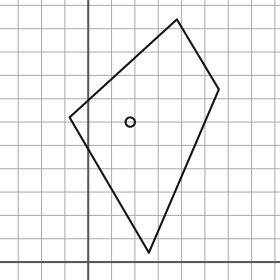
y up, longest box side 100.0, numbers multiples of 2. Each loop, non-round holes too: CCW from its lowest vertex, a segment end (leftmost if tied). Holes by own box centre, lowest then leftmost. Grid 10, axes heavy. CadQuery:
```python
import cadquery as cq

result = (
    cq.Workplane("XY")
    .moveTo(26.0, 4.0)
    .lineTo(56.0, 74.0)
    .lineTo(38.0, 104.0)
    .lineTo(-8.0, 62.0)
    .close()
    .moveTo(18.0, 60.0)
    .circle(2.0)
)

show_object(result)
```